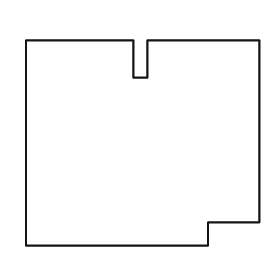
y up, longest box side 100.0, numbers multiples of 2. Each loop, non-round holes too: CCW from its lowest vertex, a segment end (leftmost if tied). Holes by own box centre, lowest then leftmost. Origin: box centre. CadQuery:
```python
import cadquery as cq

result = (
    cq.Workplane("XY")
    .moveTo(-50.0, -44.0)
    .lineTo(28.0, -44.0)
    .lineTo(28.0, -34.0)
    .lineTo(50.0, -34.0)
    .lineTo(50.0, 44.0)
    .lineTo(2.0, 44.0)
    .lineTo(2.0, 28.0)
    .lineTo(-4.0, 28.0)
    .lineTo(-4.0, 44.0)
    .lineTo(-50.0, 44.0)
    .close()
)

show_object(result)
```